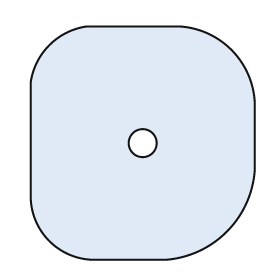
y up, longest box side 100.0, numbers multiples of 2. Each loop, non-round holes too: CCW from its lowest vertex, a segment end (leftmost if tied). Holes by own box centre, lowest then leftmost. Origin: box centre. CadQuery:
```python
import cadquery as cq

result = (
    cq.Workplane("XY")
    .moveTo(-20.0, -50.0)
    .lineTo(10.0, -50.0)
    .threePointArc((36.0, -38.0), (48.0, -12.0))
    .lineTo(48.0, 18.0)
    .threePointArc((38.0, 40.0), (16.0, 50.0))
    .lineTo(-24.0, 50.0)
    .threePointArc((-40.0, 42.0), (-48.0, 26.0))
    .lineTo(-48.0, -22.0)
    .threePointArc((-40.0, -42.0), (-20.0, -50.0))
    .close()
    .moveTo(0.0, 0.0)
    .circle(6.0)
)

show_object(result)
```